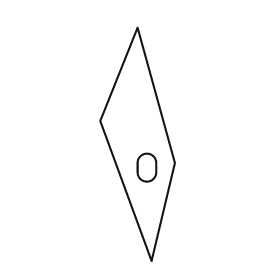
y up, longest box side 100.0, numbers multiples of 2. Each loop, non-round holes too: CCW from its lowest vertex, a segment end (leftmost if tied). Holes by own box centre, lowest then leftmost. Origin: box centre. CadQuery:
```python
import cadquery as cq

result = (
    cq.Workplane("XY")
    .moveTo(6.0, -50.0)
    .lineTo(16.0, -8.0)
    .lineTo(0.0, 50.0)
    .lineTo(-16.0, 10.0)
    .close()
    .moveTo(0.0, -12.0)
    .threePointArc((4.0, -16.0), (8.0, -12.0))
    .lineTo(8.0, -8.0)
    .threePointArc((4.0, -4.0), (0.0, -8.0))
    .close()
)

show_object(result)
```